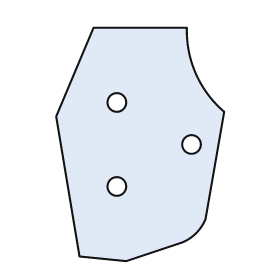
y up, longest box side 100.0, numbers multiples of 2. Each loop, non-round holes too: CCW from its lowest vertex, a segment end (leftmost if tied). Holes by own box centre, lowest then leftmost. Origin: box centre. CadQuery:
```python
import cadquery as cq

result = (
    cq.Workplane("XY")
    .moveTo(-6.0, -50.0)
    .lineTo(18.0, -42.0)
    .threePointArc((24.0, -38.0), (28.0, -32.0))
    .lineTo(36.0, 14.0)
    .threePointArc((24.0, 30.0), (20.0, 50.0))
    .lineTo(-20.0, 50.0)
    .lineTo(-36.0, 12.0)
    .lineTo(-26.0, -48.0)
    .close()
    .moveTo(-10.0, -18.0)
    .circle(4.0)
    .moveTo(22.0, 0.0)
    .circle(4.0)
    .moveTo(-10.0, 18.0)
    .circle(4.0)
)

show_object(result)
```